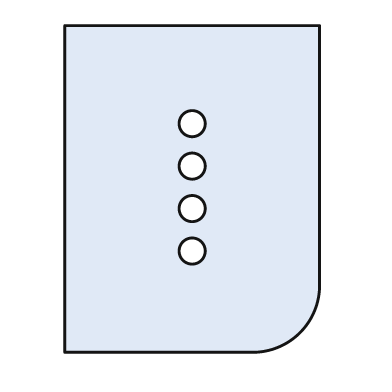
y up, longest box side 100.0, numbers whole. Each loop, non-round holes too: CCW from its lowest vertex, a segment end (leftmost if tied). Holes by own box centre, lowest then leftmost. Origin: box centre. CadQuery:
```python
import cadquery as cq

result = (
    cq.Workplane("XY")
    .moveTo(-39.0, -50.0)
    .lineTo(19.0, -50.0)
    .threePointArc((33.0, -44.0), (39.0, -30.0))
    .lineTo(39.0, 50.0)
    .lineTo(-39.0, 50.0)
    .close()
    .moveTo(0.0, -19.0)
    .circle(4.0)
    .moveTo(0.0, -6.0)
    .circle(4.0)
    .moveTo(0.0, 7.0)
    .circle(4.0)
    .moveTo(0.0, 20.0)
    .circle(4.0)
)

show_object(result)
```